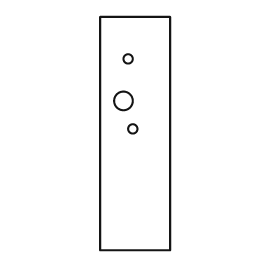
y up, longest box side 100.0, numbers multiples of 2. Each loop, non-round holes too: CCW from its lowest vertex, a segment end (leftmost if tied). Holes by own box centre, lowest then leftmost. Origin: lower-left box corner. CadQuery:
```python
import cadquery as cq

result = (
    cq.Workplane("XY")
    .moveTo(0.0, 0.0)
    .lineTo(30.0, 0.0)
    .lineTo(30.0, 100.0)
    .lineTo(0.0, 100.0)
    .close()
    .moveTo(14.0, 52.0)
    .circle(2.0)
    .moveTo(10.0, 64.0)
    .circle(4.0)
    .moveTo(12.0, 82.0)
    .circle(2.0)
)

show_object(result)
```